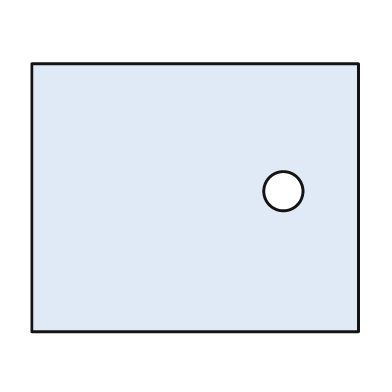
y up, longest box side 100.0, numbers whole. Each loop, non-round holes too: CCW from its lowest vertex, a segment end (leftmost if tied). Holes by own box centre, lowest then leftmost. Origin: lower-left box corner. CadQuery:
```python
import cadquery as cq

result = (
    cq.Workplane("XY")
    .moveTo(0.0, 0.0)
    .lineTo(100.0, 0.0)
    .lineTo(100.0, 82.0)
    .lineTo(0.0, 82.0)
    .close()
    .moveTo(77.0, 43.0)
    .circle(6.0)
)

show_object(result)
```